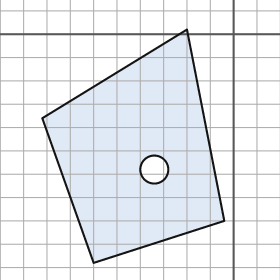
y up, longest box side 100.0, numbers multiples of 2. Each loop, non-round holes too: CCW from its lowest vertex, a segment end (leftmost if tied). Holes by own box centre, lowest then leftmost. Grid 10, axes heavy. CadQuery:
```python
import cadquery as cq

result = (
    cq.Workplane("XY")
    .moveTo(-60.0, -98.0)
    .lineTo(-4.0, -80.0)
    .lineTo(-20.0, 2.0)
    .lineTo(-82.0, -36.0)
    .close()
    .moveTo(-34.0, -58.0)
    .circle(6.0)
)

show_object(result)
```